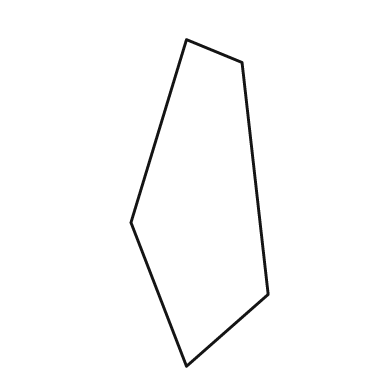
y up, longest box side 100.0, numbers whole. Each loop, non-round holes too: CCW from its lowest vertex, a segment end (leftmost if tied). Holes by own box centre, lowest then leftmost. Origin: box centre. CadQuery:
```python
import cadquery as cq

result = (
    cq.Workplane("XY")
    .moveTo(-4.0, -50.0)
    .lineTo(21.0, -28.0)
    .lineTo(13.0, 43.0)
    .lineTo(-4.0, 50.0)
    .lineTo(-21.0, -6.0)
    .close()
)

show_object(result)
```